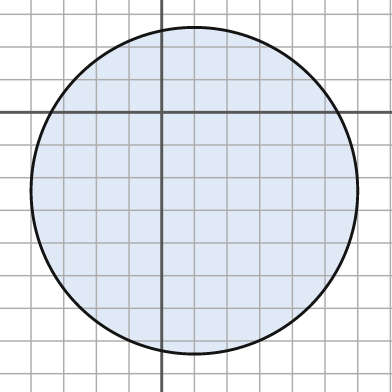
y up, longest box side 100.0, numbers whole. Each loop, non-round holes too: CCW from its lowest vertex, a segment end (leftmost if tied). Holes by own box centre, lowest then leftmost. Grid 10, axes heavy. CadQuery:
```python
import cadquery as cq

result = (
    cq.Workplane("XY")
    .moveTo(10.0, -24.0)
    .circle(50.0)
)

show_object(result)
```